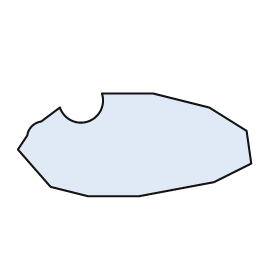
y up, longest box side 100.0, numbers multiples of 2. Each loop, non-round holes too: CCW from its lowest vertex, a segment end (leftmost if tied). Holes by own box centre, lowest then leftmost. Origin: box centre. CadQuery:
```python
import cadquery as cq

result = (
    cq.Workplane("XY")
    .moveTo(-20.0, -22.0)
    .lineTo(2.0, -22.0)
    .lineTo(34.0, -16.0)
    .lineTo(50.0, -8.0)
    .lineTo(48.0, 6.0)
    .lineTo(32.0, 16.0)
    .lineTo(8.0, 22.0)
    .lineTo(-14.0, 22.0)
    .threePointArc((-20.0, 10.0), (-32.0, 16.0))
    .lineTo(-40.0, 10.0)
    .threePointArc((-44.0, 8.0), (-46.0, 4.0))
    .lineTo(-50.0, -2.0)
    .lineTo(-36.0, -18.0)
    .close()
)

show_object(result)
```